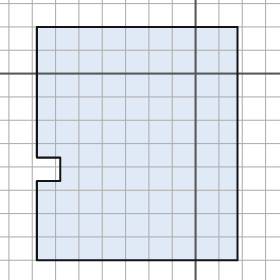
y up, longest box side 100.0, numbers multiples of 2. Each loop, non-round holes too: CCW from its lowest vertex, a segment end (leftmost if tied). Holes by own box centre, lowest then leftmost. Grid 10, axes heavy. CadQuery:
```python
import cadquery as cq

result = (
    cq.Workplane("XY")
    .moveTo(-68.0, -80.0)
    .lineTo(18.0, -80.0)
    .lineTo(18.0, 20.0)
    .lineTo(-68.0, 20.0)
    .lineTo(-68.0, -36.0)
    .lineTo(-58.0, -36.0)
    .lineTo(-58.0, -46.0)
    .lineTo(-68.0, -46.0)
    .close()
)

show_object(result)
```